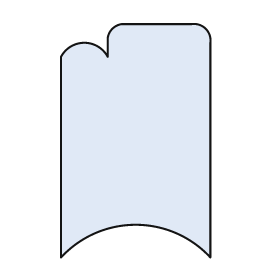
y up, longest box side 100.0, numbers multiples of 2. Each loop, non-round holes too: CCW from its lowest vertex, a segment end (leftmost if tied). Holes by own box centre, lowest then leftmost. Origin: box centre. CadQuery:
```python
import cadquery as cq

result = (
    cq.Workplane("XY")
    .moveTo(-32.0, -50.0)
    .threePointArc((0.0, -36.0), (32.0, -50.0))
    .lineTo(32.0, 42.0)
    .threePointArc((30.0, 48.0), (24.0, 50.0))
    .lineTo(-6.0, 50.0)
    .threePointArc((-10.0, 48.0), (-12.0, 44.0))
    .lineTo(-12.0, 36.0)
    .threePointArc((-22.0, 42.0), (-32.0, 36.0))
    .close()
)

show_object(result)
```